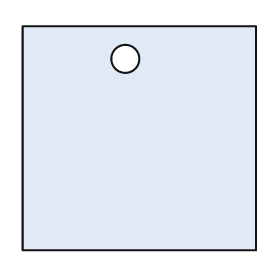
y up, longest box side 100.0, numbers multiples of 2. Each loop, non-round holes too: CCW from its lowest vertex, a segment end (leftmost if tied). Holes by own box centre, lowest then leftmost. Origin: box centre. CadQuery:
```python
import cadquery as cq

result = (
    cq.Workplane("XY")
    .moveTo(-50.0, -48.0)
    .lineTo(50.0, -48.0)
    .lineTo(50.0, 48.0)
    .lineTo(-50.0, 48.0)
    .close()
    .moveTo(-6.0, 34.0)
    .circle(6.0)
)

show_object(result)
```